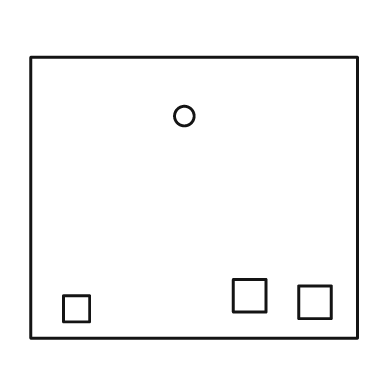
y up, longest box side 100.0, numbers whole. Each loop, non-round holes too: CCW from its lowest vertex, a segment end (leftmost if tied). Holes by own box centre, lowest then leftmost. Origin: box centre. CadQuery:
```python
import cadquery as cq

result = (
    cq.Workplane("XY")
    .moveTo(-50.0, -43.0)
    .lineTo(50.0, -43.0)
    .lineTo(50.0, 43.0)
    .lineTo(-50.0, 43.0)
    .close()
    .moveTo(-40.0, -38.0)
    .lineTo(-32.0, -38.0)
    .lineTo(-32.0, -30.0)
    .lineTo(-40.0, -30.0)
    .close()
    .moveTo(32.0, -37.0)
    .lineTo(42.0, -37.0)
    .lineTo(42.0, -27.0)
    .lineTo(32.0, -27.0)
    .close()
    .moveTo(12.0, -35.0)
    .lineTo(22.0, -35.0)
    .lineTo(22.0, -25.0)
    .lineTo(12.0, -25.0)
    .close()
    .moveTo(-3.0, 25.0)
    .circle(3.0)
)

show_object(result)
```